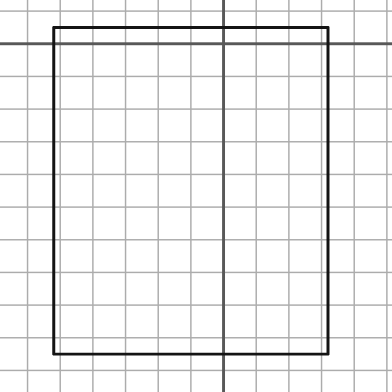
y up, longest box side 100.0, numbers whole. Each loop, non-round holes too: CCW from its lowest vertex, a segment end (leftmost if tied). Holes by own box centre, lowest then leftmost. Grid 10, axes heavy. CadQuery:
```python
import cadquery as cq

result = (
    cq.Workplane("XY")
    .moveTo(-52.0, -95.0)
    .lineTo(32.0, -95.0)
    .lineTo(32.0, 5.0)
    .lineTo(-52.0, 5.0)
    .close()
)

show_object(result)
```